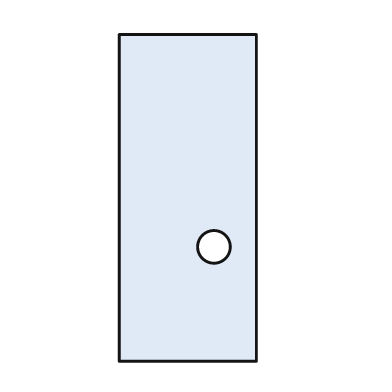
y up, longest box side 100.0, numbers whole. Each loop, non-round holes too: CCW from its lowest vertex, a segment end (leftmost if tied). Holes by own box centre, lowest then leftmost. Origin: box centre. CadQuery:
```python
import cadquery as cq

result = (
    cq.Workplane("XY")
    .moveTo(-21.0, -50.0)
    .lineTo(21.0, -50.0)
    .lineTo(21.0, 50.0)
    .lineTo(-21.0, 50.0)
    .close()
    .moveTo(8.0, -15.0)
    .circle(5.0)
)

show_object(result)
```